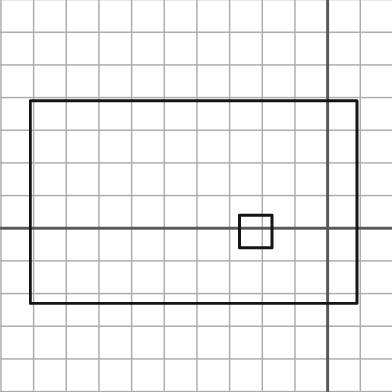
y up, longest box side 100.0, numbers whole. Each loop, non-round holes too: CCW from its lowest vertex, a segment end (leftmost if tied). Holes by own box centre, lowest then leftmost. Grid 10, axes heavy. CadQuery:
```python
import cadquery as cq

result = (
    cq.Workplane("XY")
    .moveTo(-91.0, -23.0)
    .lineTo(9.0, -23.0)
    .lineTo(9.0, 39.0)
    .lineTo(-91.0, 39.0)
    .close()
    .moveTo(-27.0, -6.0)
    .lineTo(-17.0, -6.0)
    .lineTo(-17.0, 4.0)
    .lineTo(-27.0, 4.0)
    .close()
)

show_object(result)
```